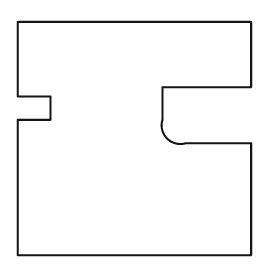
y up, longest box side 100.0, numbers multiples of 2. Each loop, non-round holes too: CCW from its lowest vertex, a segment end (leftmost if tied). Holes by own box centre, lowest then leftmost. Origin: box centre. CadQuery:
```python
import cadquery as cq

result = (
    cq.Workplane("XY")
    .moveTo(-50.0, -50.0)
    .lineTo(50.0, -50.0)
    .lineTo(50.0, -2.0)
    .lineTo(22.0, -2.0)
    .threePointArc((14.0, 0.0), (12.0, 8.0))
    .lineTo(12.0, 22.0)
    .lineTo(50.0, 22.0)
    .lineTo(50.0, 50.0)
    .lineTo(-50.0, 50.0)
    .lineTo(-50.0, 18.0)
    .lineTo(-36.0, 18.0)
    .lineTo(-36.0, 8.0)
    .lineTo(-50.0, 8.0)
    .close()
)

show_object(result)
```